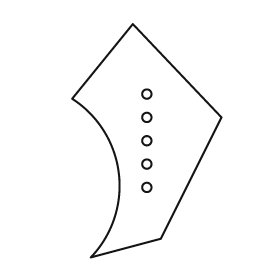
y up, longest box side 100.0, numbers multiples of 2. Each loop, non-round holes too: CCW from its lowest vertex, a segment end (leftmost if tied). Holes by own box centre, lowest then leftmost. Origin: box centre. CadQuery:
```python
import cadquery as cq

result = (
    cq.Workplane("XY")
    .moveTo(-24.0, -50.0)
    .lineTo(6.0, -42.0)
    .lineTo(32.0, 10.0)
    .lineTo(-6.0, 50.0)
    .lineTo(-32.0, 18.0)
    .threePointArc((-12.0, -14.0), (-24.0, -50.0))
    .close()
    .moveTo(0.0, -20.0)
    .circle(2.0)
    .moveTo(0.0, -10.0)
    .circle(2.0)
    .moveTo(0.0, 0.0)
    .circle(2.0)
    .moveTo(0.0, 10.0)
    .circle(2.0)
    .moveTo(0.0, 20.0)
    .circle(2.0)
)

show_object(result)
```